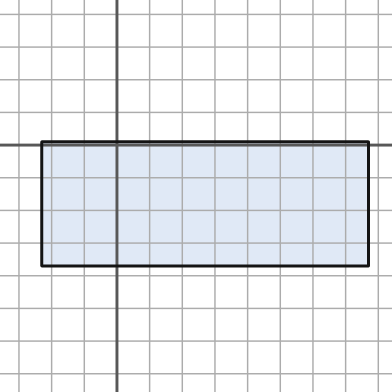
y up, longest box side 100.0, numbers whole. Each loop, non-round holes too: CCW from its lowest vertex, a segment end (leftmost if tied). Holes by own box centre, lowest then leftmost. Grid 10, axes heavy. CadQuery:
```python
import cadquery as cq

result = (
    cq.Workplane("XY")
    .moveTo(-23.0, -37.0)
    .lineTo(77.0, -37.0)
    .lineTo(77.0, 1.0)
    .lineTo(-23.0, 1.0)
    .close()
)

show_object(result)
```